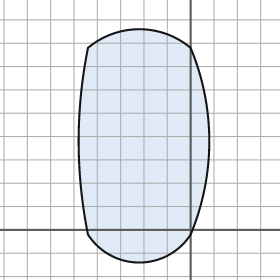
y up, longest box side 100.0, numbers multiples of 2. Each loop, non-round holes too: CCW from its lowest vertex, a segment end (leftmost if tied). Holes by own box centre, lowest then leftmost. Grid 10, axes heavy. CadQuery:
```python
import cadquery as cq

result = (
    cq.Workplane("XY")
    .moveTo(-44.0, -2.0)
    .threePointArc((-22.0, -14.0), (0.0, -2.0))
    .threePointArc((8.0, 38.0), (0.0, 78.0))
    .threePointArc((-22.0, 86.0), (-44.0, 78.0))
    .threePointArc((-48.0, 38.0), (-44.0, -2.0))
    .close()
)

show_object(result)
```